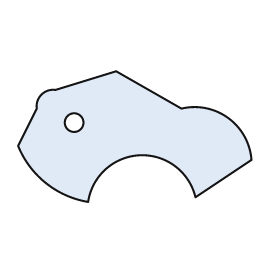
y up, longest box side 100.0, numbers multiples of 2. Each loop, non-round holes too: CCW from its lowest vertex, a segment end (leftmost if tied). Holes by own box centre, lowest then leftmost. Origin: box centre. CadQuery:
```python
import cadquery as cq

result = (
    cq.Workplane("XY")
    .moveTo(-20.0, -28.0)
    .threePointArc((2.0, -8.0), (26.0, -26.0))
    .lineTo(50.0, -10.0)
    .threePointArc((40.0, 8.0), (20.0, 12.0))
    .lineTo(-8.0, 28.0)
    .lineTo(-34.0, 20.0)
    .threePointArc((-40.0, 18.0), (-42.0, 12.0))
    .lineTo(-50.0, -4.0)
    .threePointArc((-38.0, -20.0), (-20.0, -28.0))
    .close()
    .moveTo(-26.0, 6.0)
    .circle(4.0)
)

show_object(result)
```